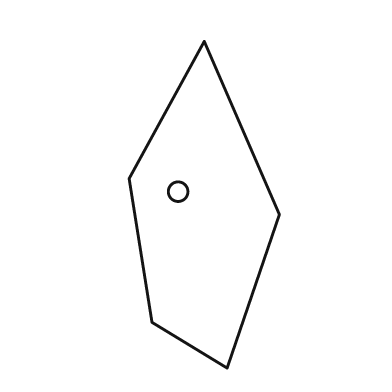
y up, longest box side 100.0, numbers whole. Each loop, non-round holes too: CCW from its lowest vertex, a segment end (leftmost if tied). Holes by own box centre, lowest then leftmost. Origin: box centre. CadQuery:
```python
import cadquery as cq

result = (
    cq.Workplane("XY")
    .moveTo(7.0, -50.0)
    .lineTo(23.0, -3.0)
    .lineTo(0.0, 50.0)
    .lineTo(-23.0, 8.0)
    .lineTo(-16.0, -36.0)
    .close()
    .moveTo(-8.0, 4.0)
    .circle(3.0)
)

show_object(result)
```